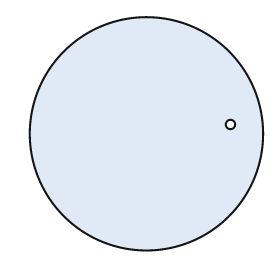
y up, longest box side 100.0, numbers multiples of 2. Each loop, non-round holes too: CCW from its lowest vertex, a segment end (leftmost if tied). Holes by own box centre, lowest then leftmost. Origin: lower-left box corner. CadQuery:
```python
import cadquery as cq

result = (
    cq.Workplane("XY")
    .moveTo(50.0, 50.0)
    .circle(50.0)
    .moveTo(86.0, 54.0)
    .circle(2.0)
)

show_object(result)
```